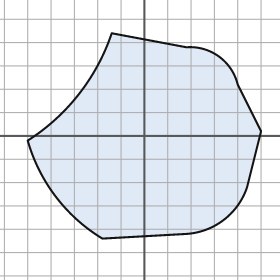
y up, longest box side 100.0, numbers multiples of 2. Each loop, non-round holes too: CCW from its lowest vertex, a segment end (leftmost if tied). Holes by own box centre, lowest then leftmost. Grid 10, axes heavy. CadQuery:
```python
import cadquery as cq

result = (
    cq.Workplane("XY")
    .moveTo(-18.0, -44.0)
    .lineTo(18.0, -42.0)
    .threePointArc((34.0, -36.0), (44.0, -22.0))
    .lineTo(50.0, 2.0)
    .lineTo(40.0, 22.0)
    .threePointArc((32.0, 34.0), (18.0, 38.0))
    .lineTo(-14.0, 44.0)
    .threePointArc((-28.0, 18.0), (-50.0, -2.0))
    .threePointArc((-38.0, -26.0), (-18.0, -44.0))
    .close()
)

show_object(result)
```